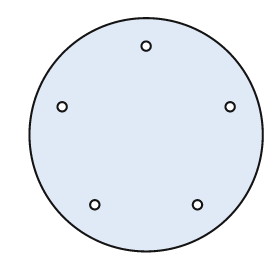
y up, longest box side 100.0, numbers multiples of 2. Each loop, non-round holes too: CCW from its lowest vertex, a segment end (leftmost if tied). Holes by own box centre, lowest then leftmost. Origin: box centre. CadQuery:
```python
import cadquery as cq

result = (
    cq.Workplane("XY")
    .moveTo(0.0, 0.0)
    .circle(50.0)
    .moveTo(-22.0, -30.0)
    .circle(2.0)
    .moveTo(22.0, -30.0)
    .circle(2.0)
    .moveTo(-36.0, 12.0)
    .circle(2.0)
    .moveTo(36.0, 12.0)
    .circle(2.0)
    .moveTo(0.0, 38.0)
    .circle(2.0)
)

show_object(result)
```